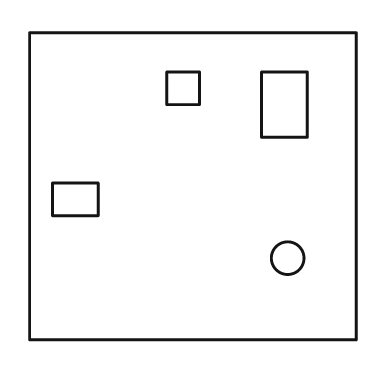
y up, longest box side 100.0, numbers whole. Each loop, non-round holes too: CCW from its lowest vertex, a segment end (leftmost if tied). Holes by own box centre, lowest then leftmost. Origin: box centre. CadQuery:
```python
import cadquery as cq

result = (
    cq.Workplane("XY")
    .moveTo(-50.0, -47.0)
    .lineTo(50.0, -47.0)
    .lineTo(50.0, 47.0)
    .lineTo(-50.0, 47.0)
    .close()
    .moveTo(29.0, -22.0)
    .circle(5.0)
    .moveTo(-43.0, -9.0)
    .lineTo(-29.0, -9.0)
    .lineTo(-29.0, 1.0)
    .lineTo(-43.0, 1.0)
    .close()
    .moveTo(21.0, 15.0)
    .lineTo(35.0, 15.0)
    .lineTo(35.0, 35.0)
    .lineTo(21.0, 35.0)
    .close()
    .moveTo(-8.0, 25.0)
    .lineTo(2.0, 25.0)
    .lineTo(2.0, 35.0)
    .lineTo(-8.0, 35.0)
    .close()
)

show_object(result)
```